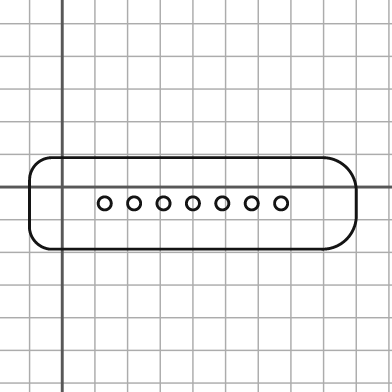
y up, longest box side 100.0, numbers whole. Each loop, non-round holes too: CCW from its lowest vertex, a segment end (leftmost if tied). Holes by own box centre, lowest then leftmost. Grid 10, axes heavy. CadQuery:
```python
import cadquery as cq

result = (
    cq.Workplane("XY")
    .moveTo(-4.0, -19.0)
    .lineTo(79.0, -19.0)
    .threePointArc((87.0, -16.0), (90.0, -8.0))
    .lineTo(90.0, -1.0)
    .threePointArc((87.0, 6.0), (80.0, 9.0))
    .lineTo(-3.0, 9.0)
    .threePointArc((-8.0, 7.0), (-10.0, 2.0))
    .lineTo(-10.0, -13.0)
    .threePointArc((-8.0, -17.0), (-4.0, -19.0))
    .close()
    .moveTo(13.0, -5.0)
    .circle(2.0)
    .moveTo(22.0, -5.0)
    .circle(2.0)
    .moveTo(31.0, -5.0)
    .circle(2.0)
    .moveTo(40.0, -5.0)
    .circle(2.0)
    .moveTo(49.0, -5.0)
    .circle(2.0)
    .moveTo(58.0, -5.0)
    .circle(2.0)
    .moveTo(67.0, -5.0)
    .circle(2.0)
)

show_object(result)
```